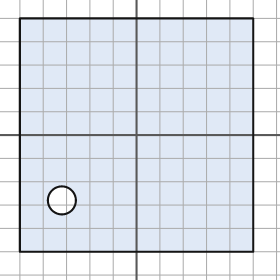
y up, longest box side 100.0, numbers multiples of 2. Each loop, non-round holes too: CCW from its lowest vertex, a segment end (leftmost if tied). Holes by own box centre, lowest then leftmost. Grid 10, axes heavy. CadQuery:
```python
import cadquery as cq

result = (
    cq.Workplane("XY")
    .moveTo(-50.0, -50.0)
    .lineTo(50.0, -50.0)
    .lineTo(50.0, 50.0)
    .lineTo(-50.0, 50.0)
    .close()
    .moveTo(-32.0, -28.0)
    .circle(6.0)
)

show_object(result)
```